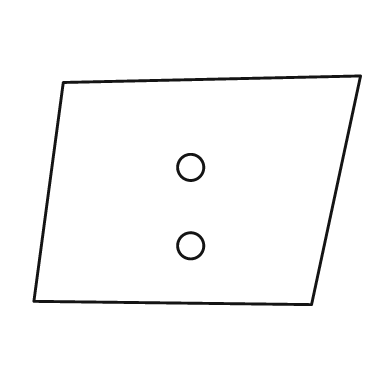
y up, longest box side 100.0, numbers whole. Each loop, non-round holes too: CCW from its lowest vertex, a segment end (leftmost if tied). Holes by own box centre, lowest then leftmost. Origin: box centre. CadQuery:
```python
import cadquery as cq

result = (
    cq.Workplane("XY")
    .moveTo(35.0, -35.0)
    .lineTo(50.0, 35.0)
    .lineTo(-41.0, 33.0)
    .lineTo(-50.0, -34.0)
    .close()
    .moveTo(-2.0, -17.0)
    .circle(4.0)
    .moveTo(-2.0, 7.0)
    .circle(4.0)
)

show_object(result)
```